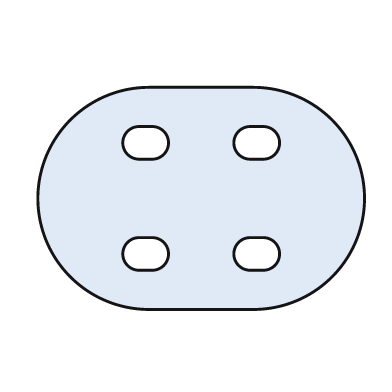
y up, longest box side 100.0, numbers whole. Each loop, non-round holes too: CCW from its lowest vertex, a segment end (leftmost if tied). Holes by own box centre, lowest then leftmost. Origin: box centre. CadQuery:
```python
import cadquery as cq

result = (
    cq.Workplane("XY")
    .moveTo(-16.0, -34.0)
    .lineTo(16.0, -34.0)
    .threePointArc((50.0, 0.0), (16.0, 34.0))
    .lineTo(-16.0, 34.0)
    .threePointArc((-50.0, 0.0), (-16.0, -34.0))
    .close()
    .moveTo(-19.0, -22.0)
    .lineTo(-15.0, -22.0)
    .threePointArc((-10.0, -17.0), (-15.0, -12.0))
    .lineTo(-19.0, -12.0)
    .threePointArc((-24.0, -17.0), (-19.0, -22.0))
    .close()
    .moveTo(15.0, -22.0)
    .lineTo(19.0, -22.0)
    .threePointArc((24.0, -17.0), (19.0, -12.0))
    .lineTo(15.0, -12.0)
    .threePointArc((10.0, -17.0), (15.0, -22.0))
    .close()
    .moveTo(-19.0, 12.0)
    .lineTo(-15.0, 12.0)
    .threePointArc((-10.0, 17.0), (-15.0, 22.0))
    .lineTo(-19.0, 22.0)
    .threePointArc((-24.0, 17.0), (-19.0, 12.0))
    .close()
    .moveTo(15.0, 12.0)
    .lineTo(19.0, 12.0)
    .threePointArc((24.0, 17.0), (19.0, 22.0))
    .lineTo(15.0, 22.0)
    .threePointArc((10.0, 17.0), (15.0, 12.0))
    .close()
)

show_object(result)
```